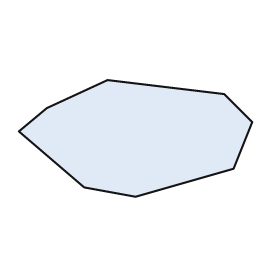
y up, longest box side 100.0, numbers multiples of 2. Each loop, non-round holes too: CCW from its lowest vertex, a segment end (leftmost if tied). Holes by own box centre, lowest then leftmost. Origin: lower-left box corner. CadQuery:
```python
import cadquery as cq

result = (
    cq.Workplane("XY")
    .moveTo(50.0, 0.0)
    .lineTo(92.0, 12.0)
    .lineTo(100.0, 32.0)
    .lineTo(88.0, 44.0)
    .lineTo(38.0, 50.0)
    .lineTo(12.0, 38.0)
    .lineTo(0.0, 28.0)
    .lineTo(28.0, 4.0)
    .close()
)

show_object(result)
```